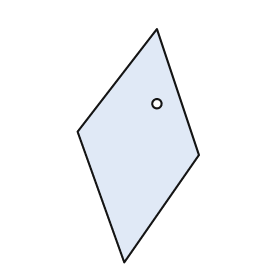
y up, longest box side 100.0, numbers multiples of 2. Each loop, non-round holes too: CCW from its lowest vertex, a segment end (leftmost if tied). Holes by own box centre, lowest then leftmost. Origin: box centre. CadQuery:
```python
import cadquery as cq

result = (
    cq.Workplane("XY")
    .moveTo(-6.0, -50.0)
    .lineTo(26.0, -4.0)
    .lineTo(8.0, 50.0)
    .lineTo(-26.0, 6.0)
    .close()
    .moveTo(8.0, 18.0)
    .circle(2.0)
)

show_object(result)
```